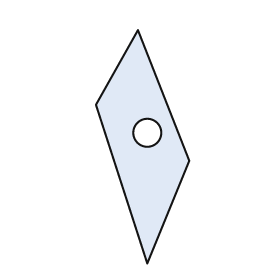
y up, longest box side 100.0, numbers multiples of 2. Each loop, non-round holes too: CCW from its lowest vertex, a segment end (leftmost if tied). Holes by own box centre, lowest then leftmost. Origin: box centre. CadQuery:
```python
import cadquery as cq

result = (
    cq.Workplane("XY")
    .moveTo(2.0, -50.0)
    .lineTo(20.0, -6.0)
    .lineTo(-2.0, 50.0)
    .lineTo(-20.0, 18.0)
    .close()
    .moveTo(2.0, 6.0)
    .circle(6.0)
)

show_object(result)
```